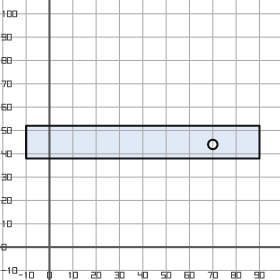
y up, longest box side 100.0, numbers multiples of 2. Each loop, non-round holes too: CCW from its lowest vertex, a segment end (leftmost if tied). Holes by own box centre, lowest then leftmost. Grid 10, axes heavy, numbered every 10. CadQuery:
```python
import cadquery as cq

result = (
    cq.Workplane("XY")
    .moveTo(-10.0, 38.0)
    .lineTo(90.0, 38.0)
    .lineTo(90.0, 52.0)
    .lineTo(-10.0, 52.0)
    .close()
    .moveTo(70.0, 44.0)
    .circle(2.0)
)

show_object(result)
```